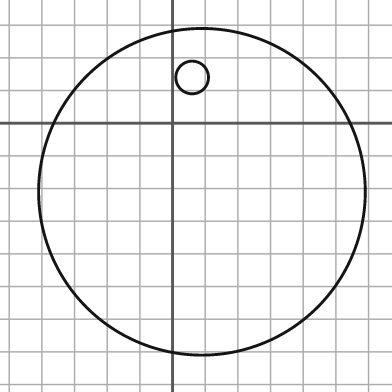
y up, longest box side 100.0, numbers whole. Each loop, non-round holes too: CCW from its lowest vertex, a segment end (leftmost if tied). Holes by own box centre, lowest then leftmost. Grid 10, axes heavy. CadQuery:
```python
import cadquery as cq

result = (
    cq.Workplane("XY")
    .moveTo(9.0, -21.0)
    .circle(50.0)
    .moveTo(6.0, 14.0)
    .circle(5.0)
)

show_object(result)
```